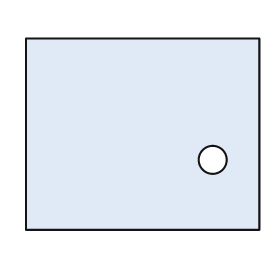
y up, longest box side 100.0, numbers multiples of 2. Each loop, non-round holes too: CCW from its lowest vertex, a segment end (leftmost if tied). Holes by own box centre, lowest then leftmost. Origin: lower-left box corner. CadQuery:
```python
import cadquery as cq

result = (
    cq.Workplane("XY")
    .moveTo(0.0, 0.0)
    .lineTo(100.0, 0.0)
    .lineTo(100.0, 82.0)
    .lineTo(0.0, 82.0)
    .close()
    .moveTo(80.0, 30.0)
    .circle(6.0)
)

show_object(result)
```